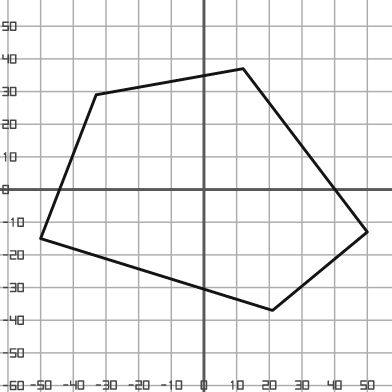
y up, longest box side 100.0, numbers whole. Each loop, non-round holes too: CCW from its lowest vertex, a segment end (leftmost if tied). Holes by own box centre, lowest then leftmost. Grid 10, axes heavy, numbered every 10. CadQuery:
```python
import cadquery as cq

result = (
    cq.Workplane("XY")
    .moveTo(21.0, -37.0)
    .lineTo(50.0, -13.0)
    .lineTo(12.0, 37.0)
    .lineTo(-33.0, 29.0)
    .lineTo(-50.0, -15.0)
    .close()
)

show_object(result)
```